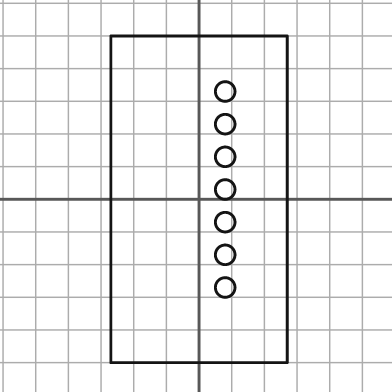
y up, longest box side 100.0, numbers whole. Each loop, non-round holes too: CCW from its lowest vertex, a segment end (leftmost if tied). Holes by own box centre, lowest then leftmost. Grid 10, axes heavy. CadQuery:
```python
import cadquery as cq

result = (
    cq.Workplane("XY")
    .moveTo(-27.0, -50.0)
    .lineTo(27.0, -50.0)
    .lineTo(27.0, 50.0)
    .lineTo(-27.0, 50.0)
    .close()
    .moveTo(8.0, -27.0)
    .circle(3.0)
    .moveTo(8.0, -17.0)
    .circle(3.0)
    .moveTo(8.0, -7.0)
    .circle(3.0)
    .moveTo(8.0, 3.0)
    .circle(3.0)
    .moveTo(8.0, 13.0)
    .circle(3.0)
    .moveTo(8.0, 23.0)
    .circle(3.0)
    .moveTo(8.0, 33.0)
    .circle(3.0)
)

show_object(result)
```